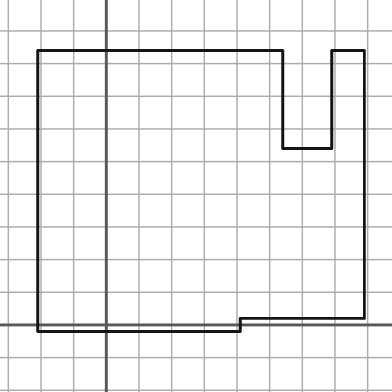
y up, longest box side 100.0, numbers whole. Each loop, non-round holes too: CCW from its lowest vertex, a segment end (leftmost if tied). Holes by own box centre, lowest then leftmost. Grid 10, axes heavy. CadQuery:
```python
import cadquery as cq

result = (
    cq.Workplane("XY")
    .moveTo(-21.0, -2.0)
    .lineTo(41.0, -2.0)
    .lineTo(41.0, 2.0)
    .lineTo(79.0, 2.0)
    .lineTo(79.0, 84.0)
    .lineTo(69.0, 84.0)
    .lineTo(69.0, 54.0)
    .lineTo(54.0, 54.0)
    .lineTo(54.0, 84.0)
    .lineTo(-21.0, 84.0)
    .close()
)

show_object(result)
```